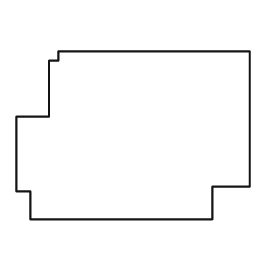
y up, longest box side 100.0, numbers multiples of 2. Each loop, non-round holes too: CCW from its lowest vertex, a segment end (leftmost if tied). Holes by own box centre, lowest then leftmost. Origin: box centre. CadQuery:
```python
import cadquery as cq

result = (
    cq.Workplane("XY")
    .moveTo(-44.0, -36.0)
    .lineTo(34.0, -36.0)
    .lineTo(34.0, -22.0)
    .lineTo(50.0, -22.0)
    .lineTo(50.0, 36.0)
    .lineTo(-32.0, 36.0)
    .lineTo(-32.0, 32.0)
    .lineTo(-36.0, 32.0)
    .lineTo(-36.0, 8.0)
    .lineTo(-50.0, 8.0)
    .lineTo(-50.0, -24.0)
    .lineTo(-44.0, -24.0)
    .close()
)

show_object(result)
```